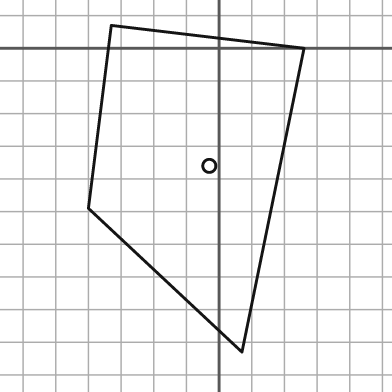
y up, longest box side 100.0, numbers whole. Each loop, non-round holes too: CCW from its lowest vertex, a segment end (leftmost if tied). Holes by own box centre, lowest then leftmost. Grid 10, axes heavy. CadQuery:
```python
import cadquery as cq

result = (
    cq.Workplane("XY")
    .moveTo(7.0, -93.0)
    .lineTo(26.0, 0.0)
    .lineTo(-33.0, 7.0)
    .lineTo(-40.0, -49.0)
    .close()
    .moveTo(-3.0, -36.0)
    .circle(2.0)
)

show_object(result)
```